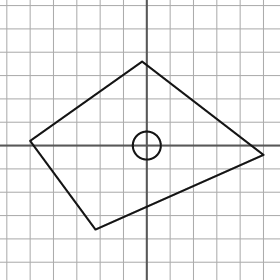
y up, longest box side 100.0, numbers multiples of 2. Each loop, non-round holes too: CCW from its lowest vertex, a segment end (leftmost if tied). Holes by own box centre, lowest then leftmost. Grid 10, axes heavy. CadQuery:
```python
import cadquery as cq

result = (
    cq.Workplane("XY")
    .moveTo(-22.0, -36.0)
    .lineTo(50.0, -4.0)
    .lineTo(-2.0, 36.0)
    .lineTo(-50.0, 2.0)
    .close()
    .moveTo(0.0, 0.0)
    .circle(6.0)
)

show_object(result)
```